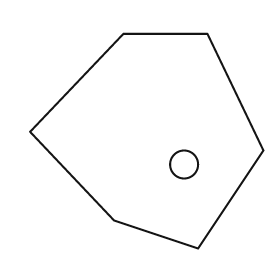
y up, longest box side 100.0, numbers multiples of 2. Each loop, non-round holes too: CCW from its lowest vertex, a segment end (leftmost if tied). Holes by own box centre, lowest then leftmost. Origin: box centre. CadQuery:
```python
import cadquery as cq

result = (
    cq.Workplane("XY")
    .moveTo(22.0, -46.0)
    .lineTo(50.0, -4.0)
    .lineTo(26.0, 46.0)
    .lineTo(-10.0, 46.0)
    .lineTo(-50.0, 4.0)
    .lineTo(-14.0, -34.0)
    .close()
    .moveTo(16.0, -10.0)
    .circle(6.0)
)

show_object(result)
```